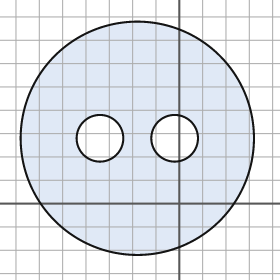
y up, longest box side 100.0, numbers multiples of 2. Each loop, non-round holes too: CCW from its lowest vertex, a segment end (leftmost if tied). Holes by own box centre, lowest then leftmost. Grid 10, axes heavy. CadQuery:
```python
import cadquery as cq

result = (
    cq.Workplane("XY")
    .moveTo(-18.0, 28.0)
    .circle(50.0)
    .moveTo(-34.0, 28.0)
    .circle(10.0)
    .moveTo(-2.0, 28.0)
    .circle(10.0)
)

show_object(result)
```